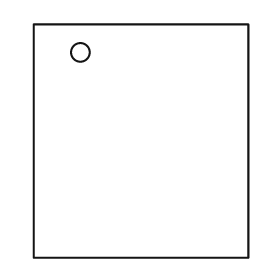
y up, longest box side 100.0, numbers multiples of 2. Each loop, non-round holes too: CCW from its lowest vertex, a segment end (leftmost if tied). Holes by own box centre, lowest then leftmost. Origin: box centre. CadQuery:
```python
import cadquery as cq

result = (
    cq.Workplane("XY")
    .moveTo(-46.0, -50.0)
    .lineTo(46.0, -50.0)
    .lineTo(46.0, 50.0)
    .lineTo(-46.0, 50.0)
    .close()
    .moveTo(-26.0, 38.0)
    .circle(4.0)
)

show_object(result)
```